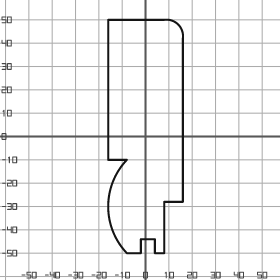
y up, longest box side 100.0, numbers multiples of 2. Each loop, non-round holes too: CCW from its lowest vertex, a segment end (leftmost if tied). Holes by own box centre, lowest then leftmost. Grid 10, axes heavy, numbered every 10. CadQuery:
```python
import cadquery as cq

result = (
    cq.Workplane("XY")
    .moveTo(-8.0, -50.0)
    .lineTo(-2.0, -50.0)
    .lineTo(-2.0, -44.0)
    .lineTo(4.0, -44.0)
    .lineTo(4.0, -50.0)
    .lineTo(8.0, -50.0)
    .lineTo(8.0, -28.0)
    .lineTo(16.0, -28.0)
    .lineTo(16.0, 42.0)
    .threePointArc((14.0, 48.0), (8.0, 50.0))
    .lineTo(-16.0, 50.0)
    .lineTo(-16.0, -10.0)
    .lineTo(-8.0, -10.0)
    .threePointArc((-16.0, -30.0), (-8.0, -50.0))
    .close()
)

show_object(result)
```